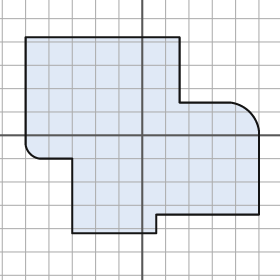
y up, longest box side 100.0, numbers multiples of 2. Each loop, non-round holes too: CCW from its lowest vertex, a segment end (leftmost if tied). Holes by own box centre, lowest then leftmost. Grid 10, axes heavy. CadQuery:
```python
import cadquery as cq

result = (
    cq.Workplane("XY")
    .moveTo(-30.0, -42.0)
    .lineTo(6.0, -42.0)
    .lineTo(6.0, -34.0)
    .lineTo(50.0, -34.0)
    .lineTo(50.0, 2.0)
    .threePointArc((46.0, 10.0), (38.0, 14.0))
    .lineTo(16.0, 14.0)
    .lineTo(16.0, 42.0)
    .lineTo(-50.0, 42.0)
    .lineTo(-50.0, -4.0)
    .threePointArc((-48.0, -8.0), (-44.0, -10.0))
    .lineTo(-30.0, -10.0)
    .close()
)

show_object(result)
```